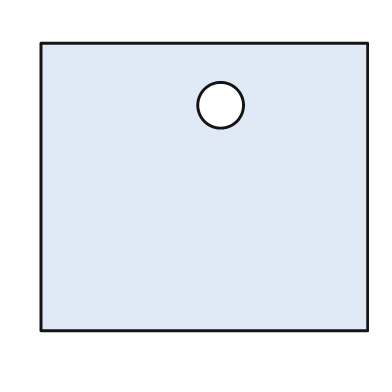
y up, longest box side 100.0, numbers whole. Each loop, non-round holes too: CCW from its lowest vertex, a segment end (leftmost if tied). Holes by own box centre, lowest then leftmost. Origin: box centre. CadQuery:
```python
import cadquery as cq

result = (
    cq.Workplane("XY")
    .moveTo(-50.0, -44.0)
    .lineTo(50.0, -44.0)
    .lineTo(50.0, 44.0)
    .lineTo(-50.0, 44.0)
    .close()
    .moveTo(5.0, 25.0)
    .circle(7.0)
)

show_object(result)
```